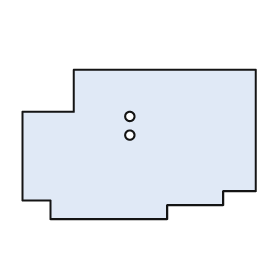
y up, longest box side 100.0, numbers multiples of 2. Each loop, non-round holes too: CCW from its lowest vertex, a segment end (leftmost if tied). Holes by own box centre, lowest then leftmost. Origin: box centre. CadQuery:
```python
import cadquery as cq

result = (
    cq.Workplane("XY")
    .moveTo(-38.0, -32.0)
    .lineTo(12.0, -32.0)
    .lineTo(12.0, -26.0)
    .lineTo(36.0, -26.0)
    .lineTo(36.0, -20.0)
    .lineTo(50.0, -20.0)
    .lineTo(50.0, 32.0)
    .lineTo(-28.0, 32.0)
    .lineTo(-28.0, 14.0)
    .lineTo(-50.0, 14.0)
    .lineTo(-50.0, -24.0)
    .lineTo(-38.0, -24.0)
    .close()
    .moveTo(-4.0, 4.0)
    .circle(2.0)
    .moveTo(-4.0, 12.0)
    .circle(2.0)
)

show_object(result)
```